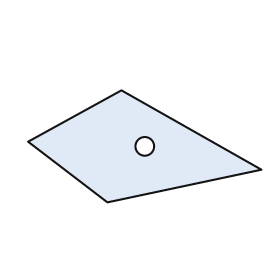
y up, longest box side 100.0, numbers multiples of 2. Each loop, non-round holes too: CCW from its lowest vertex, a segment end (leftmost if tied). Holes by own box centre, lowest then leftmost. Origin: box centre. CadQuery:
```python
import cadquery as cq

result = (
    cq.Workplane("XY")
    .moveTo(-16.0, -24.0)
    .lineTo(50.0, -10.0)
    .lineTo(-10.0, 24.0)
    .lineTo(-50.0, 2.0)
    .close()
    .moveTo(0.0, 0.0)
    .circle(4.0)
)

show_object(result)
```